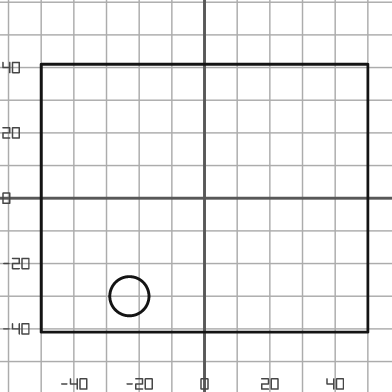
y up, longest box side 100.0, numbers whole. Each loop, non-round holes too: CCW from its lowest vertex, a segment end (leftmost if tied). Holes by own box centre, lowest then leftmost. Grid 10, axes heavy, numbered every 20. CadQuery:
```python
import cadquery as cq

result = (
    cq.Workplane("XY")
    .moveTo(-50.0, -41.0)
    .lineTo(50.0, -41.0)
    .lineTo(50.0, 41.0)
    .lineTo(-50.0, 41.0)
    .close()
    .moveTo(-23.0, -30.0)
    .circle(6.0)
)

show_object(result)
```